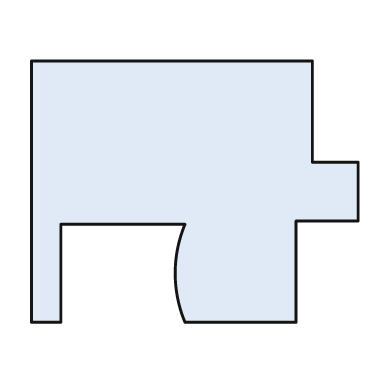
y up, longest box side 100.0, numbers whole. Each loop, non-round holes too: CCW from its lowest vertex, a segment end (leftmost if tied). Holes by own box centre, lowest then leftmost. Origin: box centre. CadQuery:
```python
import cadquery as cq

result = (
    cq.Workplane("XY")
    .moveTo(-50.0, -40.0)
    .lineTo(-41.0, -40.0)
    .lineTo(-41.0, -10.0)
    .lineTo(-3.0, -10.0)
    .threePointArc((-6.0, -25.0), (-3.0, -40.0))
    .lineTo(31.0, -40.0)
    .lineTo(31.0, -9.0)
    .lineTo(50.0, -9.0)
    .lineTo(50.0, 9.0)
    .lineTo(36.0, 9.0)
    .lineTo(36.0, 40.0)
    .lineTo(-50.0, 40.0)
    .close()
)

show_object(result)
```